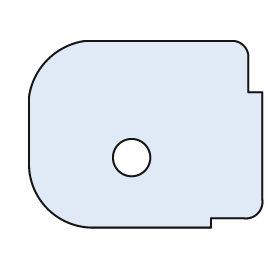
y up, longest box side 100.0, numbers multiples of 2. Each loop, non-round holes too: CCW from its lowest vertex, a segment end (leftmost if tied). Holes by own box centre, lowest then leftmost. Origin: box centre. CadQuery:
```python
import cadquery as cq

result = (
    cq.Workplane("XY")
    .moveTo(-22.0, -40.0)
    .lineTo(28.0, -40.0)
    .lineTo(28.0, -36.0)
    .lineTo(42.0, -36.0)
    .threePointArc((48.0, -34.0), (50.0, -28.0))
    .lineTo(50.0, 18.0)
    .lineTo(44.0, 18.0)
    .lineTo(44.0, 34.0)
    .threePointArc((42.0, 38.0), (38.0, 40.0))
    .lineTo(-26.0, 40.0)
    .threePointArc((-42.0, 32.0), (-50.0, 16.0))
    .lineTo(-50.0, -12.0)
    .threePointArc((-42.0, -32.0), (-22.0, -40.0))
    .close()
    .moveTo(-6.0, -10.0)
    .circle(8.0)
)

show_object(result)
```